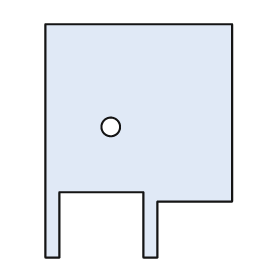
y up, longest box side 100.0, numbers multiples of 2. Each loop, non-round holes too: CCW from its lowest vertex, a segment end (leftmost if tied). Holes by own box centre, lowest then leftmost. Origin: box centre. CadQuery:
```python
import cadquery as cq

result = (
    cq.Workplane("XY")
    .moveTo(-40.0, -50.0)
    .lineTo(-34.0, -50.0)
    .lineTo(-34.0, -22.0)
    .lineTo(2.0, -22.0)
    .lineTo(2.0, -50.0)
    .lineTo(8.0, -50.0)
    .lineTo(8.0, -26.0)
    .lineTo(40.0, -26.0)
    .lineTo(40.0, 50.0)
    .lineTo(-40.0, 50.0)
    .close()
    .moveTo(-12.0, 6.0)
    .circle(4.0)
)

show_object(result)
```